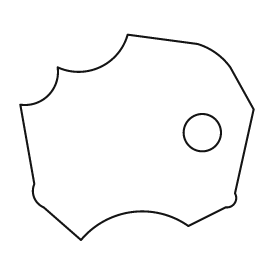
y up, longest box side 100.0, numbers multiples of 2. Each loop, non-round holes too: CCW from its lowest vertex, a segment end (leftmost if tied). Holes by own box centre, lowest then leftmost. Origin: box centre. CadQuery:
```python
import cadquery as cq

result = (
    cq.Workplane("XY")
    .moveTo(-24.0, -44.0)
    .threePointArc((-2.0, -32.0), (22.0, -38.0))
    .lineTo(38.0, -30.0)
    .threePointArc((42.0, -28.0), (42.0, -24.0))
    .lineTo(50.0, 12.0)
    .lineTo(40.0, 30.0)
    .threePointArc((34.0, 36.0), (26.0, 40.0))
    .lineTo(-4.0, 44.0)
    .threePointArc((-16.0, 30.0), (-34.0, 30.0))
    .threePointArc((-38.0, 18.0), (-50.0, 14.0))
    .lineTo(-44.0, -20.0)
    .threePointArc((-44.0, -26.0), (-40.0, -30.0))
    .close()
    .moveTo(28.0, 2.0)
    .circle(8.0)
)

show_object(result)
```